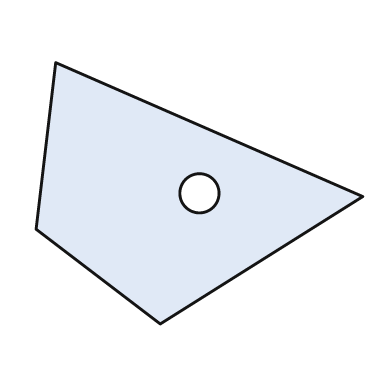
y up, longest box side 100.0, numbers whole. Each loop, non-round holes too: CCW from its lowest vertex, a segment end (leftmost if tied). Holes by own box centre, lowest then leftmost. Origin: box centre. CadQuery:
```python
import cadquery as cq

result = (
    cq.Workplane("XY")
    .moveTo(-12.0, -40.0)
    .lineTo(50.0, -1.0)
    .lineTo(-44.0, 40.0)
    .lineTo(-50.0, -11.0)
    .close()
    .moveTo(0.0, 0.0)
    .circle(6.0)
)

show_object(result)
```